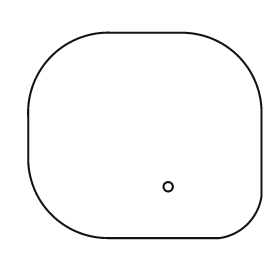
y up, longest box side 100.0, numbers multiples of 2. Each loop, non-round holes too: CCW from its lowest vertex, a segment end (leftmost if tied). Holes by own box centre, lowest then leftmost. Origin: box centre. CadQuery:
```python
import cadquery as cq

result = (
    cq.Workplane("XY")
    .moveTo(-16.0, -44.0)
    .lineTo(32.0, -44.0)
    .threePointArc((44.0, -38.0), (50.0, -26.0))
    .lineTo(50.0, 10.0)
    .threePointArc((40.0, 34.0), (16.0, 44.0))
    .lineTo(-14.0, 44.0)
    .threePointArc((-40.0, 34.0), (-50.0, 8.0))
    .lineTo(-50.0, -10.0)
    .threePointArc((-40.0, -34.0), (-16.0, -44.0))
    .close()
    .moveTo(10.0, -22.0)
    .circle(2.0)
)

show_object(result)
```